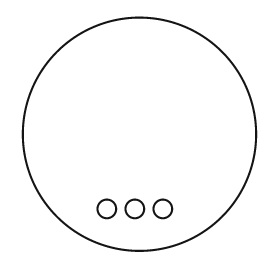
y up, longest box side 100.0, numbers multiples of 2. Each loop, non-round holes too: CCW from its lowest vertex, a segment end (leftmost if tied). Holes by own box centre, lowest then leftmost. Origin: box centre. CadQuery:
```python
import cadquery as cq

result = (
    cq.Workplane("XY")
    .moveTo(0.0, 0.0)
    .circle(50.0)
    .moveTo(-14.0, -32.0)
    .circle(4.0)
    .moveTo(-2.0, -32.0)
    .circle(4.0)
    .moveTo(10.0, -32.0)
    .circle(4.0)
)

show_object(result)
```